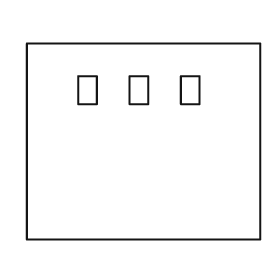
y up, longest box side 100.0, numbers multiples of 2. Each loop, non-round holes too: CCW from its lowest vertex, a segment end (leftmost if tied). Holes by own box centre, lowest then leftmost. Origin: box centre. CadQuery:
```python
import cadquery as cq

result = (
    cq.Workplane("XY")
    .moveTo(-50.0, -42.0)
    .lineTo(50.0, -42.0)
    .lineTo(50.0, 42.0)
    .lineTo(-50.0, 42.0)
    .close()
    .moveTo(-28.0, 16.0)
    .lineTo(-20.0, 16.0)
    .lineTo(-20.0, 28.0)
    .lineTo(-28.0, 28.0)
    .close()
    .moveTo(-6.0, 16.0)
    .lineTo(2.0, 16.0)
    .lineTo(2.0, 28.0)
    .lineTo(-6.0, 28.0)
    .close()
    .moveTo(16.0, 16.0)
    .lineTo(24.0, 16.0)
    .lineTo(24.0, 28.0)
    .lineTo(16.0, 28.0)
    .close()
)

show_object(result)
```